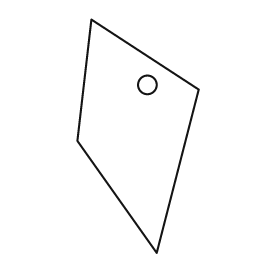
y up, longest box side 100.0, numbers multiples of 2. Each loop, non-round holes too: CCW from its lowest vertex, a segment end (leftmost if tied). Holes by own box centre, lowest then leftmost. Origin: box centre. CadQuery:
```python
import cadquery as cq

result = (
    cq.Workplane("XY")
    .moveTo(8.0, -50.0)
    .lineTo(26.0, 20.0)
    .lineTo(-20.0, 50.0)
    .lineTo(-26.0, -2.0)
    .close()
    .moveTo(4.0, 22.0)
    .circle(4.0)
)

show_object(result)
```